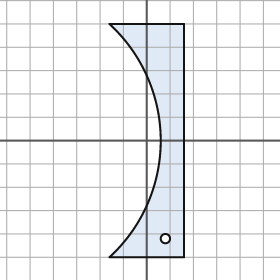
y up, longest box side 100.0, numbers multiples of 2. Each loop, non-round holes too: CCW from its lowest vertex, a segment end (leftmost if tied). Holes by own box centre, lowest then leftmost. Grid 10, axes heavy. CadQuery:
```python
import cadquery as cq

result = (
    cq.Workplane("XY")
    .moveTo(-16.0, -50.0)
    .lineTo(16.0, -50.0)
    .lineTo(16.0, 50.0)
    .lineTo(-16.0, 50.0)
    .threePointArc((6.0, 0.0), (-16.0, -50.0))
    .close()
    .moveTo(8.0, -42.0)
    .circle(2.0)
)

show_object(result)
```